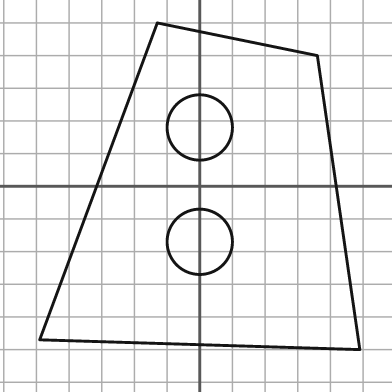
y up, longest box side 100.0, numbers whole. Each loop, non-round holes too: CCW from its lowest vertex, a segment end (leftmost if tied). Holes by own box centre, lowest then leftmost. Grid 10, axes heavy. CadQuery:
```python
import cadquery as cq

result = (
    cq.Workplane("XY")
    .moveTo(49.0, -50.0)
    .lineTo(36.0, 40.0)
    .lineTo(-13.0, 50.0)
    .lineTo(-49.0, -47.0)
    .close()
    .moveTo(0.0, -17.0)
    .circle(10.0)
    .moveTo(0.0, 18.0)
    .circle(10.0)
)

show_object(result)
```